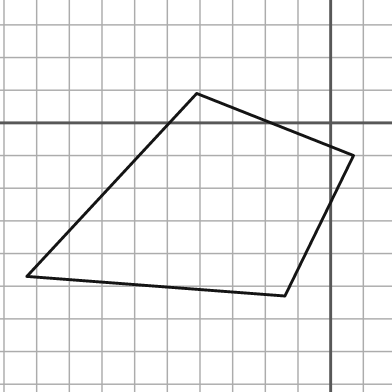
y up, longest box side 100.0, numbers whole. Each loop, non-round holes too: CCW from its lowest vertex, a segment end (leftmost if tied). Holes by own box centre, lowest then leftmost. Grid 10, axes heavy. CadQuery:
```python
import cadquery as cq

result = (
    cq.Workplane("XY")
    .moveTo(-14.0, -53.0)
    .lineTo(7.0, -10.0)
    .lineTo(-41.0, 9.0)
    .lineTo(-93.0, -47.0)
    .close()
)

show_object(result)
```